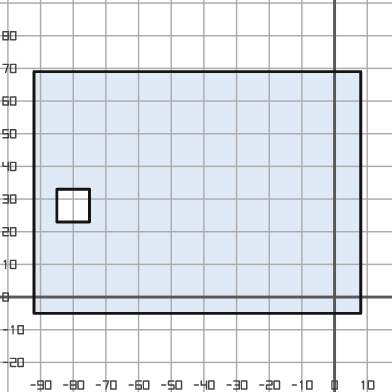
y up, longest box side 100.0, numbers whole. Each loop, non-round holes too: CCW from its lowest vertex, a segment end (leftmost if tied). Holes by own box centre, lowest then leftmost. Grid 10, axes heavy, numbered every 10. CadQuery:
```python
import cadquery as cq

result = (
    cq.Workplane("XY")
    .moveTo(-92.0, -5.0)
    .lineTo(8.0, -5.0)
    .lineTo(8.0, 69.0)
    .lineTo(-92.0, 69.0)
    .close()
    .moveTo(-85.0, 23.0)
    .lineTo(-75.0, 23.0)
    .lineTo(-75.0, 33.0)
    .lineTo(-85.0, 33.0)
    .close()
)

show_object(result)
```